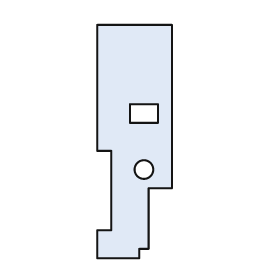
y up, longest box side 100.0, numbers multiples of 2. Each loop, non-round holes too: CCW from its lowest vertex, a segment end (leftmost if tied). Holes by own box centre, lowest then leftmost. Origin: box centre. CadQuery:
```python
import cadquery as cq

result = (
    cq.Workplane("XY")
    .moveTo(-16.0, -50.0)
    .lineTo(2.0, -50.0)
    .lineTo(2.0, -46.0)
    .lineTo(6.0, -46.0)
    .lineTo(6.0, -20.0)
    .lineTo(16.0, -20.0)
    .lineTo(16.0, 50.0)
    .lineTo(-16.0, 50.0)
    .lineTo(-16.0, -4.0)
    .lineTo(-10.0, -4.0)
    .lineTo(-10.0, -38.0)
    .lineTo(-16.0, -38.0)
    .close()
    .moveTo(4.0, -12.0)
    .circle(4.0)
    .moveTo(-2.0, 8.0)
    .lineTo(10.0, 8.0)
    .lineTo(10.0, 16.0)
    .lineTo(-2.0, 16.0)
    .close()
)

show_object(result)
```